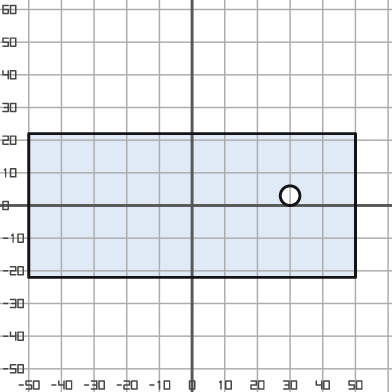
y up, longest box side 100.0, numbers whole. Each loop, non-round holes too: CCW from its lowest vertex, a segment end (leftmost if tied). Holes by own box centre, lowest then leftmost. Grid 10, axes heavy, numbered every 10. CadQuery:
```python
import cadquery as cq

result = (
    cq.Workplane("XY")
    .moveTo(-50.0, -22.0)
    .lineTo(50.0, -22.0)
    .lineTo(50.0, 22.0)
    .lineTo(-50.0, 22.0)
    .close()
    .moveTo(30.0, 3.0)
    .circle(3.0)
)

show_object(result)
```